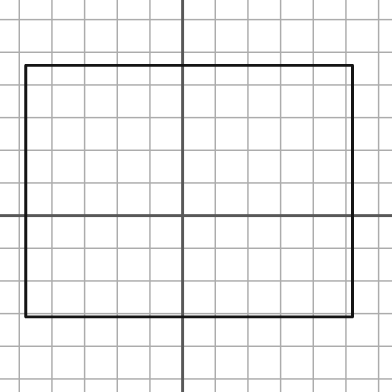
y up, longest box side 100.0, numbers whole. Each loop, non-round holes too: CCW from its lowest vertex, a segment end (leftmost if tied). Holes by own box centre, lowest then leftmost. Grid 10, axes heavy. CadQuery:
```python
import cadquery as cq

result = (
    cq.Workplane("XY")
    .moveTo(-48.0, -31.0)
    .lineTo(52.0, -31.0)
    .lineTo(52.0, 46.0)
    .lineTo(-48.0, 46.0)
    .close()
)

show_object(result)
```